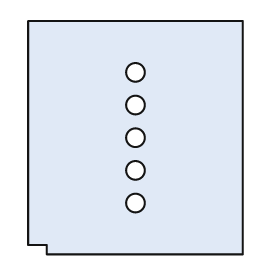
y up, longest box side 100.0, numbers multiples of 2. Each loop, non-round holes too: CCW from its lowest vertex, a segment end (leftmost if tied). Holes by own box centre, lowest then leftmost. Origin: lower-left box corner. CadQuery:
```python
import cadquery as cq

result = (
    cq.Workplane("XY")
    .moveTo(8.0, 0.0)
    .lineTo(92.0, 0.0)
    .lineTo(92.0, 100.0)
    .lineTo(0.0, 100.0)
    .lineTo(0.0, 4.0)
    .lineTo(8.0, 4.0)
    .close()
    .moveTo(46.0, 22.0)
    .circle(4.0)
    .moveTo(46.0, 36.0)
    .circle(4.0)
    .moveTo(46.0, 50.0)
    .circle(4.0)
    .moveTo(46.0, 64.0)
    .circle(4.0)
    .moveTo(46.0, 78.0)
    .circle(4.0)
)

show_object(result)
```